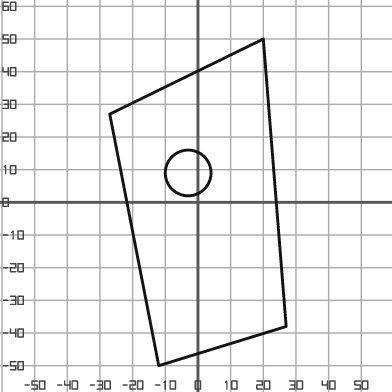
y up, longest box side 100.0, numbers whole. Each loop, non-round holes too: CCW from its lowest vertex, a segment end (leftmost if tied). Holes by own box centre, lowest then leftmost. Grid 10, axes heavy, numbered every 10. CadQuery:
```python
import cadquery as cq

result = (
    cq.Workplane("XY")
    .moveTo(-12.0, -50.0)
    .lineTo(27.0, -38.0)
    .lineTo(20.0, 50.0)
    .lineTo(-27.0, 27.0)
    .close()
    .moveTo(-3.0, 9.0)
    .circle(7.0)
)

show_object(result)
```